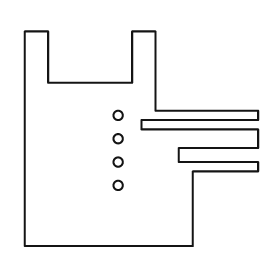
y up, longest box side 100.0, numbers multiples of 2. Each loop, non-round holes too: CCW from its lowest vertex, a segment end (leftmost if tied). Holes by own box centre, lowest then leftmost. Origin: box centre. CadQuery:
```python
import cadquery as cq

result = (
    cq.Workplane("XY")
    .moveTo(-50.0, -46.0)
    .lineTo(22.0, -46.0)
    .lineTo(22.0, -14.0)
    .lineTo(50.0, -14.0)
    .lineTo(50.0, -10.0)
    .lineTo(16.0, -10.0)
    .lineTo(16.0, -4.0)
    .lineTo(50.0, -4.0)
    .lineTo(50.0, 4.0)
    .lineTo(0.0, 4.0)
    .lineTo(0.0, 8.0)
    .lineTo(50.0, 8.0)
    .lineTo(50.0, 12.0)
    .lineTo(6.0, 12.0)
    .lineTo(6.0, 46.0)
    .lineTo(-4.0, 46.0)
    .lineTo(-4.0, 24.0)
    .lineTo(-40.0, 24.0)
    .lineTo(-40.0, 46.0)
    .lineTo(-50.0, 46.0)
    .close()
    .moveTo(-10.0, -20.0)
    .circle(2.0)
    .moveTo(-10.0, -10.0)
    .circle(2.0)
    .moveTo(-10.0, 0.0)
    .circle(2.0)
    .moveTo(-10.0, 10.0)
    .circle(2.0)
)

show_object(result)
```